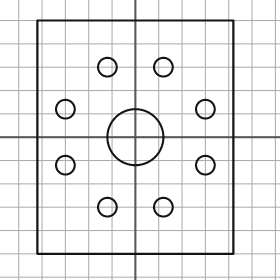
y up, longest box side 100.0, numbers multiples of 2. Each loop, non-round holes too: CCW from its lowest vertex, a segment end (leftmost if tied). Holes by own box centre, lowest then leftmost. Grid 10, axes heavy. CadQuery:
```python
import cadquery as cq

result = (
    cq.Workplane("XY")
    .moveTo(-42.0, -50.0)
    .lineTo(42.0, -50.0)
    .lineTo(42.0, 50.0)
    .lineTo(-42.0, 50.0)
    .close()
    .moveTo(-12.0, -30.0)
    .circle(4.0)
    .moveTo(12.0, -30.0)
    .circle(4.0)
    .moveTo(-30.0, -12.0)
    .circle(4.0)
    .moveTo(30.0, -12.0)
    .circle(4.0)
    .moveTo(0.0, 0.0)
    .circle(12.0)
    .moveTo(-30.0, 12.0)
    .circle(4.0)
    .moveTo(30.0, 12.0)
    .circle(4.0)
    .moveTo(-12.0, 30.0)
    .circle(4.0)
    .moveTo(12.0, 30.0)
    .circle(4.0)
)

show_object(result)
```